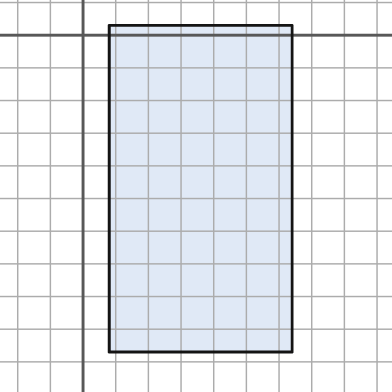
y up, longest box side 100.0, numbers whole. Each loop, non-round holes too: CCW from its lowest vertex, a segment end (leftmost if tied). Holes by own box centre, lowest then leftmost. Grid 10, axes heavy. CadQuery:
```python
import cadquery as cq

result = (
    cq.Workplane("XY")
    .moveTo(8.0, -97.0)
    .lineTo(64.0, -97.0)
    .lineTo(64.0, 3.0)
    .lineTo(8.0, 3.0)
    .close()
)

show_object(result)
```